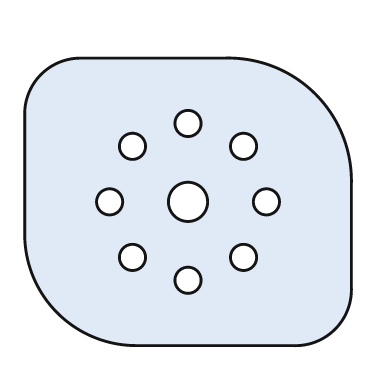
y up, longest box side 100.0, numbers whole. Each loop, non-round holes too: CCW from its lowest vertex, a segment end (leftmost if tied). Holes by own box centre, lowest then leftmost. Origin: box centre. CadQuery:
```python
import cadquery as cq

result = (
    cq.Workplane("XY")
    .moveTo(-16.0, -44.0)
    .lineTo(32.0, -44.0)
    .threePointArc((45.0, -39.0), (50.0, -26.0))
    .lineTo(50.0, 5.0)
    .threePointArc((39.0, 33.0), (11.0, 44.0))
    .lineTo(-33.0, 44.0)
    .threePointArc((-45.0, 39.0), (-50.0, 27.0))
    .lineTo(-50.0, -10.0)
    .threePointArc((-40.0, -34.0), (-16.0, -44.0))
    .close()
    .moveTo(0.0, -24.0)
    .circle(4.0)
    .moveTo(-17.0, -17.0)
    .circle(4.0)
    .moveTo(17.0, -17.0)
    .circle(4.0)
    .moveTo(-24.0, 0.0)
    .circle(4.0)
    .moveTo(0.0, 0.0)
    .circle(6.0)
    .moveTo(24.0, 0.0)
    .circle(4.0)
    .moveTo(-17.0, 17.0)
    .circle(4.0)
    .moveTo(17.0, 17.0)
    .circle(4.0)
    .moveTo(0.0, 24.0)
    .circle(4.0)
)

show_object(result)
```